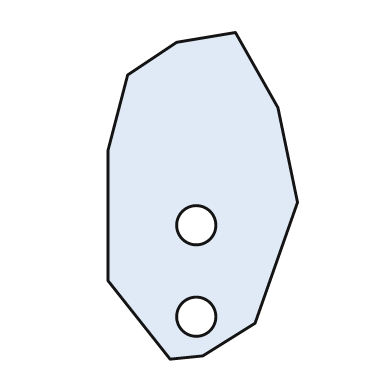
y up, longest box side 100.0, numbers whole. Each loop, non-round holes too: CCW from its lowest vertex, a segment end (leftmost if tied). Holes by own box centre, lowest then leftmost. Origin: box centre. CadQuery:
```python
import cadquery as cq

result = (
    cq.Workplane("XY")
    .moveTo(-10.0, -50.0)
    .lineTo(0.0, -49.0)
    .lineTo(16.0, -39.0)
    .lineTo(29.0, -2.0)
    .lineTo(23.0, 27.0)
    .lineTo(10.0, 50.0)
    .lineTo(-8.0, 47.0)
    .lineTo(-23.0, 37.0)
    .lineTo(-29.0, 14.0)
    .lineTo(-29.0, -26.0)
    .close()
    .moveTo(-2.0, -37.0)
    .circle(6.0)
    .moveTo(-2.0, -9.0)
    .circle(6.0)
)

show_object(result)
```